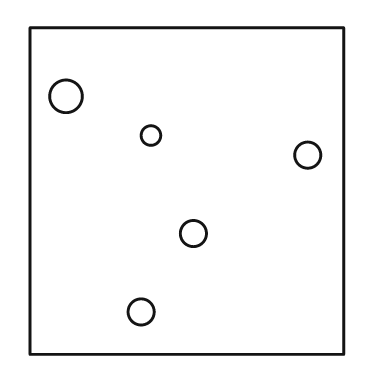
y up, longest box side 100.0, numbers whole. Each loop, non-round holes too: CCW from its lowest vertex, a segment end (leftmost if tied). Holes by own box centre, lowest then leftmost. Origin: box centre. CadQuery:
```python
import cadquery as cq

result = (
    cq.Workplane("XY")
    .moveTo(-48.0, -50.0)
    .lineTo(48.0, -50.0)
    .lineTo(48.0, 50.0)
    .lineTo(-48.0, 50.0)
    .close()
    .moveTo(-14.0, -37.0)
    .circle(4.0)
    .moveTo(2.0, -13.0)
    .circle(4.0)
    .moveTo(37.0, 11.0)
    .circle(4.0)
    .moveTo(-11.0, 17.0)
    .circle(3.0)
    .moveTo(-37.0, 29.0)
    .circle(5.0)
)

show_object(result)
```